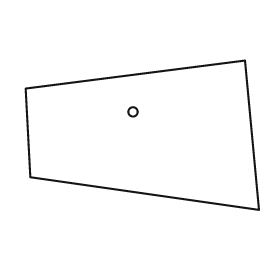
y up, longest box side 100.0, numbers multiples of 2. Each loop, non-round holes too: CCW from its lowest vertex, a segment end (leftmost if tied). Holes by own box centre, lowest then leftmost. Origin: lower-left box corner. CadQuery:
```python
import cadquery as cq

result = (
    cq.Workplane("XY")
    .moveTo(100.0, 0.0)
    .lineTo(94.0, 64.0)
    .lineTo(0.0, 52.0)
    .lineTo(2.0, 14.0)
    .close()
    .moveTo(46.0, 42.0)
    .circle(2.0)
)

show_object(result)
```